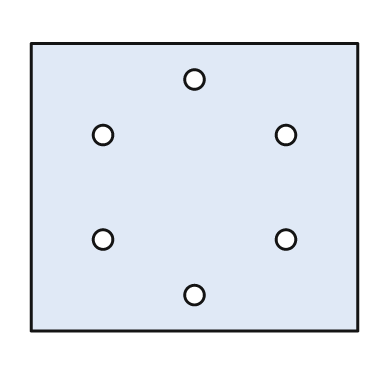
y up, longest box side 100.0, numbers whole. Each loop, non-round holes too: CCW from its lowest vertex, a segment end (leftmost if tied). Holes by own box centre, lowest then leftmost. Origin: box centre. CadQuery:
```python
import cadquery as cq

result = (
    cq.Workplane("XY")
    .moveTo(-50.0, -44.0)
    .lineTo(50.0, -44.0)
    .lineTo(50.0, 44.0)
    .lineTo(-50.0, 44.0)
    .close()
    .moveTo(0.0, -33.0)
    .circle(3.0)
    .moveTo(-28.0, -16.0)
    .circle(3.0)
    .moveTo(28.0, -16.0)
    .circle(3.0)
    .moveTo(-28.0, 16.0)
    .circle(3.0)
    .moveTo(28.0, 16.0)
    .circle(3.0)
    .moveTo(0.0, 33.0)
    .circle(3.0)
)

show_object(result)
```